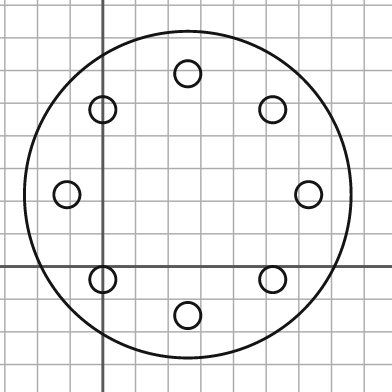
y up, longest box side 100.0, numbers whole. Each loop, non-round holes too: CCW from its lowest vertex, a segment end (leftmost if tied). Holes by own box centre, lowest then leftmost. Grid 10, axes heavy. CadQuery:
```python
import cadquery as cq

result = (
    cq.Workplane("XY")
    .moveTo(26.0, 22.0)
    .circle(50.0)
    .moveTo(26.0, -15.0)
    .circle(4.0)
    .moveTo(0.0, -4.0)
    .circle(4.0)
    .moveTo(52.0, -4.0)
    .circle(4.0)
    .moveTo(-11.0, 22.0)
    .circle(4.0)
    .moveTo(63.0, 22.0)
    .circle(4.0)
    .moveTo(0.0, 48.0)
    .circle(4.0)
    .moveTo(52.0, 48.0)
    .circle(4.0)
    .moveTo(26.0, 59.0)
    .circle(4.0)
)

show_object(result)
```